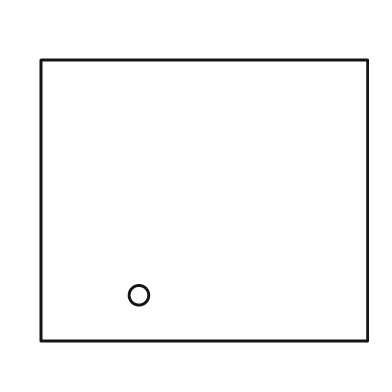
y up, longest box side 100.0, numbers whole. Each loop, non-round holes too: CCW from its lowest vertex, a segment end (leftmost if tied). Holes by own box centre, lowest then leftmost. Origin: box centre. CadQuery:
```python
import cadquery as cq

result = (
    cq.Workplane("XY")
    .moveTo(-50.0, -43.0)
    .lineTo(50.0, -43.0)
    .lineTo(50.0, 43.0)
    .lineTo(-50.0, 43.0)
    .close()
    .moveTo(-20.0, -29.0)
    .circle(3.0)
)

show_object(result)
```